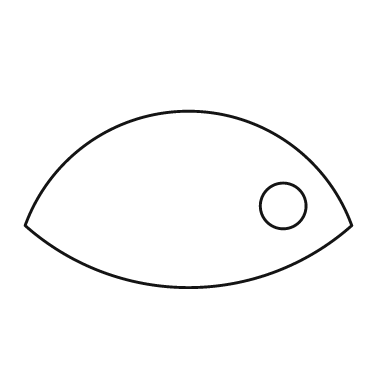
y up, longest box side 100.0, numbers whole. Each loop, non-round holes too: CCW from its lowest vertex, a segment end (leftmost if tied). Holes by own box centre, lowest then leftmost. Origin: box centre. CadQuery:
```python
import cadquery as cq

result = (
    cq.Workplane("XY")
    .moveTo(-50.0, -8.0)
    .threePointArc((0.0, -27.0), (50.0, -8.0))
    .threePointArc((0.0, 27.0), (-50.0, -8.0))
    .close()
    .moveTo(29.0, -2.0)
    .circle(7.0)
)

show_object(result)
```